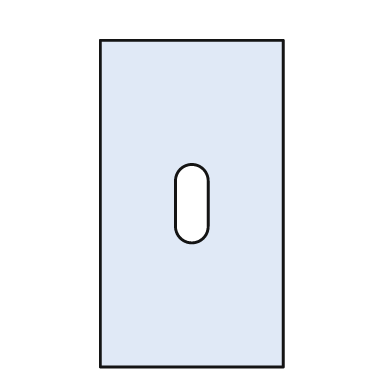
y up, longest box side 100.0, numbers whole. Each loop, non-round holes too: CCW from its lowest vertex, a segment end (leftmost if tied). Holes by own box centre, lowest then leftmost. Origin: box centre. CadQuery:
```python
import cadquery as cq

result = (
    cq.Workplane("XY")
    .moveTo(-28.0, -50.0)
    .lineTo(28.0, -50.0)
    .lineTo(28.0, 50.0)
    .lineTo(-28.0, 50.0)
    .close()
    .moveTo(-5.0, -7.0)
    .threePointArc((0.0, -12.0), (5.0, -7.0))
    .lineTo(5.0, 7.0)
    .threePointArc((0.0, 12.0), (-5.0, 7.0))
    .close()
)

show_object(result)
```